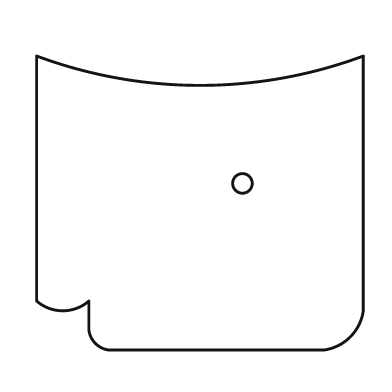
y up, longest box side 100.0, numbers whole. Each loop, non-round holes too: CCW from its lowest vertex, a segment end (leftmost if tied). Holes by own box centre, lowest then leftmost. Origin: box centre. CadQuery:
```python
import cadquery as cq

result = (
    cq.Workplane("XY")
    .moveTo(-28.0, -45.0)
    .lineTo(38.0, -45.0)
    .threePointArc((46.0, -41.0), (50.0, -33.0))
    .lineTo(50.0, 45.0)
    .threePointArc((0.0, 36.0), (-50.0, 45.0))
    .lineTo(-50.0, -30.0)
    .threePointArc((-42.0, -33.0), (-34.0, -30.0))
    .lineTo(-34.0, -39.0)
    .threePointArc((-32.0, -43.0), (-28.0, -45.0))
    .close()
    .moveTo(13.0, 6.0)
    .circle(3.0)
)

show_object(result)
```